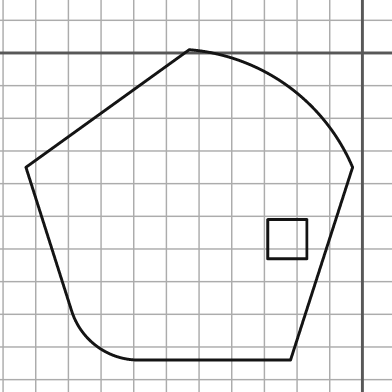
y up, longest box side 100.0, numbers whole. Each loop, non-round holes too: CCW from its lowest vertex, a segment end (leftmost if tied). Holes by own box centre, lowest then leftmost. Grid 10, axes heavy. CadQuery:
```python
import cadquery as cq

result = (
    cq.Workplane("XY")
    .moveTo(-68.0, -94.0)
    .lineTo(-22.0, -94.0)
    .lineTo(-3.0, -35.0)
    .threePointArc((-23.0, -10.0), (-53.0, 1.0))
    .lineTo(-103.0, -35.0)
    .lineTo(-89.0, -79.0)
    .threePointArc((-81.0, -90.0), (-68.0, -94.0))
    .close()
    .moveTo(-29.0, -63.0)
    .lineTo(-17.0, -63.0)
    .lineTo(-17.0, -51.0)
    .lineTo(-29.0, -51.0)
    .close()
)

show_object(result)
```